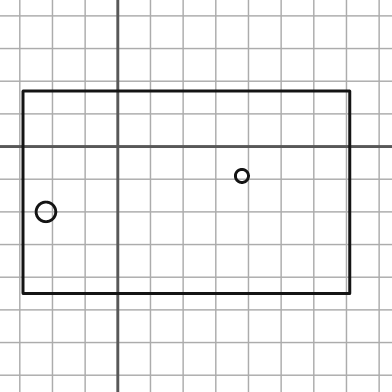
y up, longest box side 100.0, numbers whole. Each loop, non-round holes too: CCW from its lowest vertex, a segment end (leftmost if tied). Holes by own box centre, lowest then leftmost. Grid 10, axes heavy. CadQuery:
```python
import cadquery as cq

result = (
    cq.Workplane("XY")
    .moveTo(-29.0, -45.0)
    .lineTo(71.0, -45.0)
    .lineTo(71.0, 17.0)
    .lineTo(-29.0, 17.0)
    .close()
    .moveTo(-22.0, -20.0)
    .circle(3.0)
    .moveTo(38.0, -9.0)
    .circle(2.0)
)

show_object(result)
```